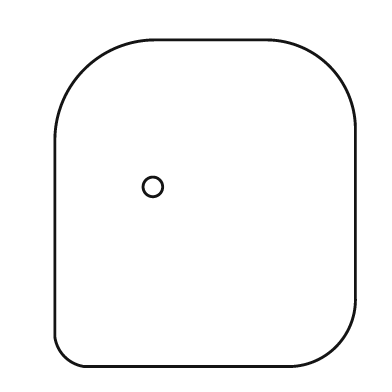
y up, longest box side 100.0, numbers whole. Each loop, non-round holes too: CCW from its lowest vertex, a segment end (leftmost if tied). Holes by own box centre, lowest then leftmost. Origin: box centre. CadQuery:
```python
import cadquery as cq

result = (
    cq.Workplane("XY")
    .moveTo(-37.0, -50.0)
    .lineTo(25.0, -50.0)
    .threePointArc((40.0, -44.0), (46.0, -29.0))
    .lineTo(46.0, 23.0)
    .threePointArc((38.0, 42.0), (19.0, 50.0))
    .lineTo(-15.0, 50.0)
    .threePointArc((-37.0, 41.0), (-46.0, 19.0))
    .lineTo(-46.0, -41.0)
    .threePointArc((-43.0, -47.0), (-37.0, -50.0))
    .close()
    .moveTo(-16.0, 5.0)
    .circle(3.0)
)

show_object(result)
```